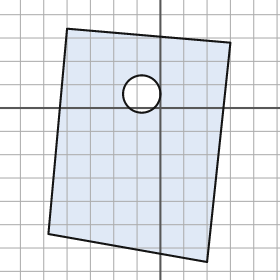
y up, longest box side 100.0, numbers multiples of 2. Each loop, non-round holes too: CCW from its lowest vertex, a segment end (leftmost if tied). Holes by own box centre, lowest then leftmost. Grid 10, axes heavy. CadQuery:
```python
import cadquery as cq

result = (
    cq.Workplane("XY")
    .moveTo(20.0, -66.0)
    .lineTo(30.0, 28.0)
    .lineTo(-40.0, 34.0)
    .lineTo(-48.0, -54.0)
    .close()
    .moveTo(-8.0, 6.0)
    .circle(8.0)
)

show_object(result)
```